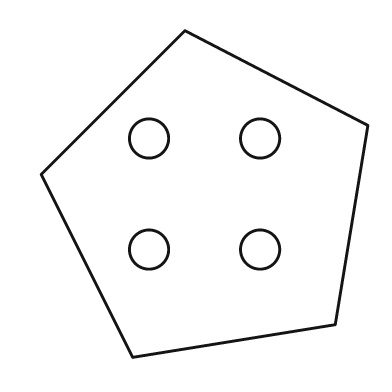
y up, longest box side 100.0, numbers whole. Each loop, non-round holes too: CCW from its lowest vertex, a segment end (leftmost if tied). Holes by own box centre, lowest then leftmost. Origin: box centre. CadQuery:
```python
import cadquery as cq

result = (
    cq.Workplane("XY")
    .moveTo(-22.0, -50.0)
    .lineTo(40.0, -40.0)
    .lineTo(50.0, 21.0)
    .lineTo(-6.0, 50.0)
    .lineTo(-50.0, 6.0)
    .close()
    .moveTo(-17.0, -17.0)
    .circle(6.0)
    .moveTo(17.0, -17.0)
    .circle(6.0)
    .moveTo(-17.0, 17.0)
    .circle(6.0)
    .moveTo(17.0, 17.0)
    .circle(6.0)
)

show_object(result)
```